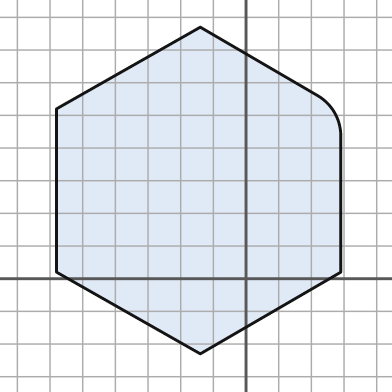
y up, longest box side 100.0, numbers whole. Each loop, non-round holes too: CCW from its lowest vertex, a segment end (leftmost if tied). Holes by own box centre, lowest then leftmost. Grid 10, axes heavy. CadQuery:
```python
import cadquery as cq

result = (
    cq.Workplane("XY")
    .moveTo(-14.0, -23.0)
    .lineTo(29.0, 2.0)
    .lineTo(29.0, 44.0)
    .threePointArc((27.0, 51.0), (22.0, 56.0))
    .lineTo(-14.0, 77.0)
    .lineTo(-58.0, 52.0)
    .lineTo(-58.0, 2.0)
    .close()
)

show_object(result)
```